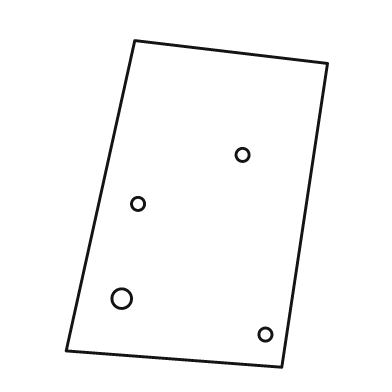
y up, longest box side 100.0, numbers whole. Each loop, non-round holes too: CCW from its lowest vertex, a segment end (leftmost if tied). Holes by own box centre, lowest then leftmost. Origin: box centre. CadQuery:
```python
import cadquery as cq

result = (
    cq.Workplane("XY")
    .moveTo(26.0, -50.0)
    .lineTo(40.0, 43.0)
    .lineTo(-19.0, 50.0)
    .lineTo(-40.0, -45.0)
    .close()
    .moveTo(21.0, -40.0)
    .circle(2.0)
    .moveTo(-23.0, -29.0)
    .circle(3.0)
    .moveTo(-18.0, 0.0)
    .circle(2.0)
    .moveTo(14.0, 15.0)
    .circle(2.0)
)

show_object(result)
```